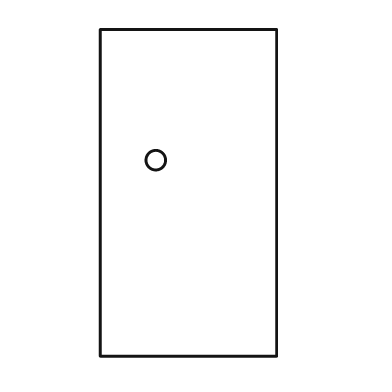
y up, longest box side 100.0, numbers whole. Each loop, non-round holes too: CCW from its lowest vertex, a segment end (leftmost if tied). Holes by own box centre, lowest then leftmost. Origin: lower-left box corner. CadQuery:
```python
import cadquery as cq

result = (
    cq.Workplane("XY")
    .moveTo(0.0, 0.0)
    .lineTo(54.0, 0.0)
    .lineTo(54.0, 100.0)
    .lineTo(0.0, 100.0)
    .close()
    .moveTo(17.0, 60.0)
    .circle(3.0)
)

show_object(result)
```